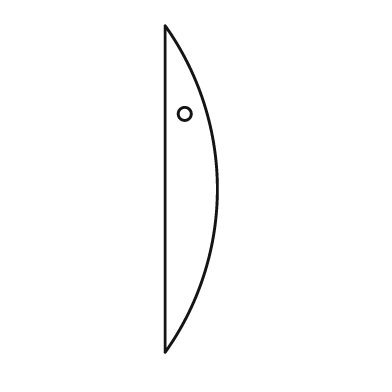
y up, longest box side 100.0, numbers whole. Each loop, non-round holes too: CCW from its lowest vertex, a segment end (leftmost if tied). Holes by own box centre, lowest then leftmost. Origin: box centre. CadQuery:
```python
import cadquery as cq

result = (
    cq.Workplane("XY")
    .moveTo(-8.0, -50.0)
    .threePointArc((8.0, 0.0), (-8.0, 50.0))
    .close()
    .moveTo(-2.0, 23.0)
    .circle(2.0)
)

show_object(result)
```